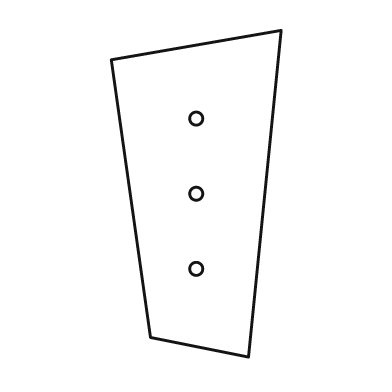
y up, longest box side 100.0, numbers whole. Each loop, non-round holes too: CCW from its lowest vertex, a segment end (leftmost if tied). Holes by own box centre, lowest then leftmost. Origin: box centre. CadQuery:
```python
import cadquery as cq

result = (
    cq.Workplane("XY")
    .moveTo(16.0, -50.0)
    .lineTo(26.0, 50.0)
    .lineTo(-26.0, 41.0)
    .lineTo(-14.0, -44.0)
    .close()
    .moveTo(0.0, -23.0)
    .circle(2.0)
    .moveTo(0.0, 0.0)
    .circle(2.0)
    .moveTo(0.0, 23.0)
    .circle(2.0)
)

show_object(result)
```